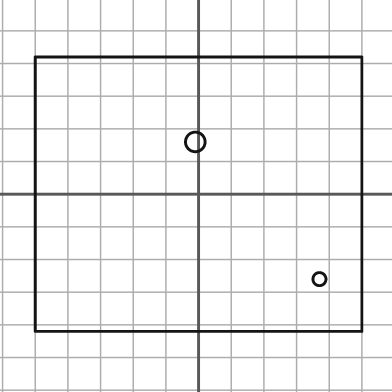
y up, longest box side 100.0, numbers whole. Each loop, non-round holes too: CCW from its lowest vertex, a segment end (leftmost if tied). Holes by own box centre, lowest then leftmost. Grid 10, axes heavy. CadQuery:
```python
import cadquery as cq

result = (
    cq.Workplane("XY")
    .moveTo(-50.0, -42.0)
    .lineTo(50.0, -42.0)
    .lineTo(50.0, 42.0)
    .lineTo(-50.0, 42.0)
    .close()
    .moveTo(37.0, -26.0)
    .circle(2.0)
    .moveTo(-1.0, 16.0)
    .circle(3.0)
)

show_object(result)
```